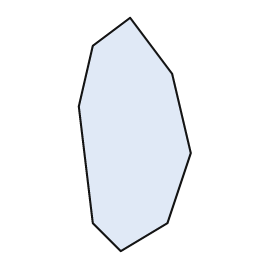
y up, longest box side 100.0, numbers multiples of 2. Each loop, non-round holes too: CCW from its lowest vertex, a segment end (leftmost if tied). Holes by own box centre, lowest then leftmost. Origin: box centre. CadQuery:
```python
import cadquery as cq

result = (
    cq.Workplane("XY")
    .moveTo(-6.0, -50.0)
    .lineTo(14.0, -38.0)
    .lineTo(24.0, -8.0)
    .lineTo(16.0, 26.0)
    .lineTo(-2.0, 50.0)
    .lineTo(-18.0, 38.0)
    .lineTo(-24.0, 12.0)
    .lineTo(-18.0, -38.0)
    .close()
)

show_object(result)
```